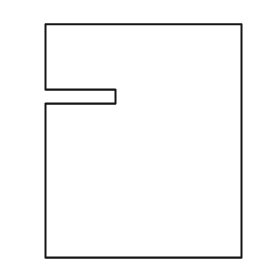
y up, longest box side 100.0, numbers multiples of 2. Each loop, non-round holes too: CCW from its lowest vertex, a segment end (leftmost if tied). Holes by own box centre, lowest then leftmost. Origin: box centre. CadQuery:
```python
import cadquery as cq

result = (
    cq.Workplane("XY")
    .moveTo(-42.0, -50.0)
    .lineTo(42.0, -50.0)
    .lineTo(42.0, 50.0)
    .lineTo(-42.0, 50.0)
    .lineTo(-42.0, 22.0)
    .lineTo(-12.0, 22.0)
    .lineTo(-12.0, 16.0)
    .lineTo(-42.0, 16.0)
    .close()
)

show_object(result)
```